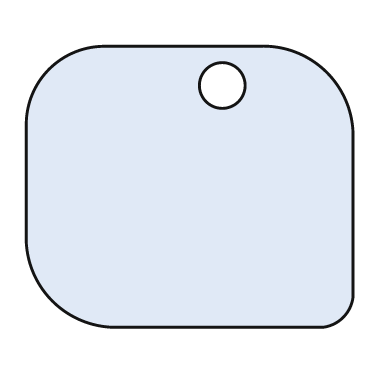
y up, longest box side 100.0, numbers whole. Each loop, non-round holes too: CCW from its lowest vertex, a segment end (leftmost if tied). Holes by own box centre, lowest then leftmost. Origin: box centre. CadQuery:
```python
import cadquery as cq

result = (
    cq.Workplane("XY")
    .moveTo(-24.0, -43.0)
    .lineTo(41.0, -43.0)
    .threePointArc((47.0, -40.0), (50.0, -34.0))
    .lineTo(50.0, 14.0)
    .threePointArc((42.0, 35.0), (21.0, 43.0))
    .lineTo(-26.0, 43.0)
    .threePointArc((-43.0, 36.0), (-50.0, 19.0))
    .lineTo(-50.0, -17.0)
    .threePointArc((-42.0, -35.0), (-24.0, -43.0))
    .close()
    .moveTo(10.0, 31.0)
    .circle(7.0)
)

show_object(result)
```